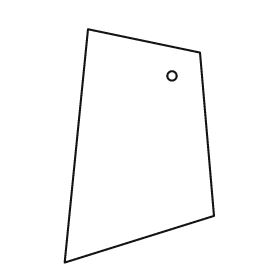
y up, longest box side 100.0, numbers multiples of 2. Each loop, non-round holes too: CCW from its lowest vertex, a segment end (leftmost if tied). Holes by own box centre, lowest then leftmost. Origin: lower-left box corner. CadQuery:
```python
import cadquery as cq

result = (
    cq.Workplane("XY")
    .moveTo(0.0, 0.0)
    .lineTo(64.0, 20.0)
    .lineTo(58.0, 90.0)
    .lineTo(10.0, 100.0)
    .close()
    .moveTo(46.0, 80.0)
    .circle(2.0)
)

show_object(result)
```